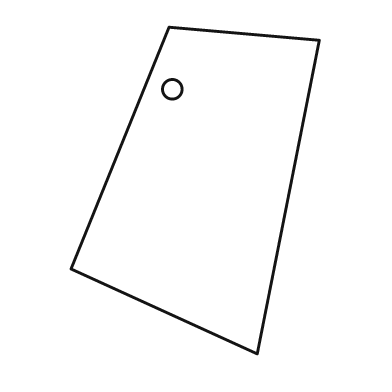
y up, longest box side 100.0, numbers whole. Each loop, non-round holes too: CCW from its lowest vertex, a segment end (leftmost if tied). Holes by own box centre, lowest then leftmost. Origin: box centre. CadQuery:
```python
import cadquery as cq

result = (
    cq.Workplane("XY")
    .moveTo(19.0, -50.0)
    .lineTo(38.0, 46.0)
    .lineTo(-8.0, 50.0)
    .lineTo(-38.0, -24.0)
    .close()
    .moveTo(-7.0, 31.0)
    .circle(3.0)
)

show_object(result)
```